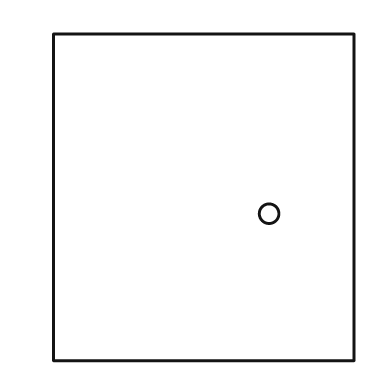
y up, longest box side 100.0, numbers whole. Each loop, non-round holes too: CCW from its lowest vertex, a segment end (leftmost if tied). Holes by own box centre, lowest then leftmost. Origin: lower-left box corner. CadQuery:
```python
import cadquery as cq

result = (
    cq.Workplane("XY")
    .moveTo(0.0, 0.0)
    .lineTo(92.0, 0.0)
    .lineTo(92.0, 100.0)
    .lineTo(0.0, 100.0)
    .close()
    .moveTo(66.0, 45.0)
    .circle(3.0)
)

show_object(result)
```